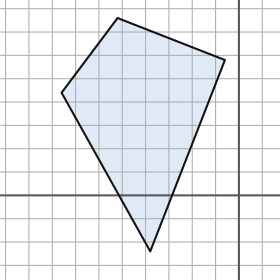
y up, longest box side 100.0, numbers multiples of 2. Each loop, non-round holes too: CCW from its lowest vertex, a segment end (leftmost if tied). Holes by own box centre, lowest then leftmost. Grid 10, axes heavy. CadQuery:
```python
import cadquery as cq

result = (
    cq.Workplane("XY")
    .moveTo(-38.0, -24.0)
    .lineTo(-6.0, 58.0)
    .lineTo(-52.0, 76.0)
    .lineTo(-76.0, 44.0)
    .close()
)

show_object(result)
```